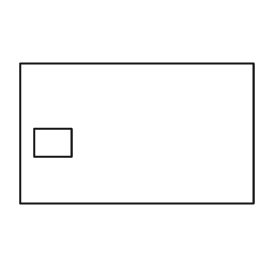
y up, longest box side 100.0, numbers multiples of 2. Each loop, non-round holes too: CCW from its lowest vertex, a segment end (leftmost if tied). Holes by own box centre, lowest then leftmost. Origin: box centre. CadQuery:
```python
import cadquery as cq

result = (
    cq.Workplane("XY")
    .moveTo(-50.0, -30.0)
    .lineTo(50.0, -30.0)
    .lineTo(50.0, 30.0)
    .lineTo(-50.0, 30.0)
    .close()
    .moveTo(-44.0, -10.0)
    .lineTo(-28.0, -10.0)
    .lineTo(-28.0, 2.0)
    .lineTo(-44.0, 2.0)
    .close()
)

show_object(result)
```